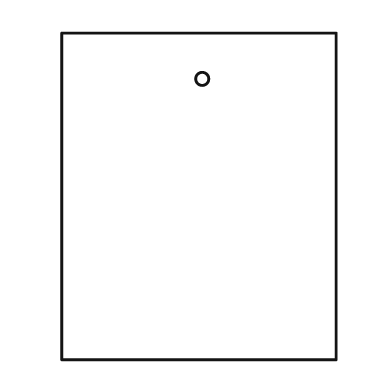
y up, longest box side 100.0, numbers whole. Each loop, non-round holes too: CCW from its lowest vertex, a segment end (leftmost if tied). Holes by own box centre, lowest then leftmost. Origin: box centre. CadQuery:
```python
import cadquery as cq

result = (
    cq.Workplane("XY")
    .moveTo(-42.0, -50.0)
    .lineTo(42.0, -50.0)
    .lineTo(42.0, 50.0)
    .lineTo(-42.0, 50.0)
    .close()
    .moveTo(1.0, 36.0)
    .circle(2.0)
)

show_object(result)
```